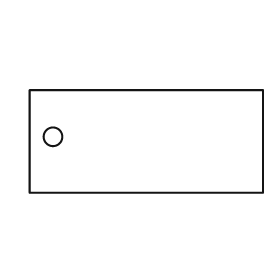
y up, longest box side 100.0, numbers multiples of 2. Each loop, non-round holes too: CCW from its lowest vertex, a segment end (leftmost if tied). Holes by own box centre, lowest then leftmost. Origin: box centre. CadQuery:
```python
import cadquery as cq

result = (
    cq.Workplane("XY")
    .moveTo(-50.0, -22.0)
    .lineTo(50.0, -22.0)
    .lineTo(50.0, 22.0)
    .lineTo(-50.0, 22.0)
    .close()
    .moveTo(-40.0, 2.0)
    .circle(4.0)
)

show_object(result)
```